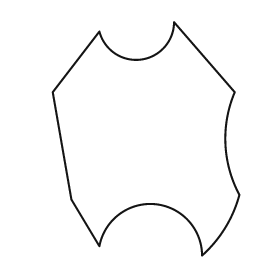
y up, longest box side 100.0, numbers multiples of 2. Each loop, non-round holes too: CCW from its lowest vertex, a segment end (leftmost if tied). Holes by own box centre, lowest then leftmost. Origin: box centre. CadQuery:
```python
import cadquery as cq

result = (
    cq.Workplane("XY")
    .moveTo(24.0, -50.0)
    .threePointArc((34.0, -38.0), (40.0, -24.0))
    .threePointArc((34.0, -2.0), (38.0, 20.0))
    .lineTo(12.0, 50.0)
    .threePointArc((-2.0, 34.0), (-20.0, 46.0))
    .lineTo(-40.0, 20.0)
    .lineTo(-32.0, -26.0)
    .lineTo(-20.0, -46.0)
    .threePointArc((4.0, -28.0), (24.0, -50.0))
    .close()
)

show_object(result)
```